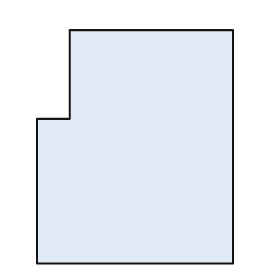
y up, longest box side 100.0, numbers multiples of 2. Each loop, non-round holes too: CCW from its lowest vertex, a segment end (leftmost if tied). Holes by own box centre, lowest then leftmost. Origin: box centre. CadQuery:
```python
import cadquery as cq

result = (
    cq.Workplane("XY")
    .moveTo(-42.0, -50.0)
    .lineTo(42.0, -50.0)
    .lineTo(42.0, 50.0)
    .lineTo(-28.0, 50.0)
    .lineTo(-28.0, 12.0)
    .lineTo(-42.0, 12.0)
    .close()
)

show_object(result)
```